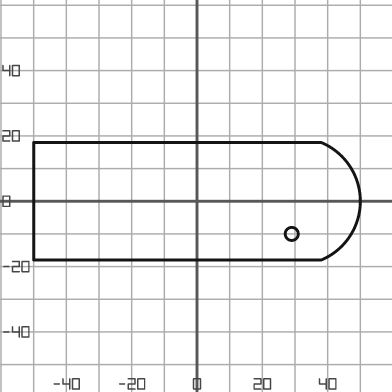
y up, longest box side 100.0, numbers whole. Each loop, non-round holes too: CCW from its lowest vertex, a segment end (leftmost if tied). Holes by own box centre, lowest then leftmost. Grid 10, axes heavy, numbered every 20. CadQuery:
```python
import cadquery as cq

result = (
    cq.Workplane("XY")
    .moveTo(-50.0, -18.0)
    .lineTo(38.0, -18.0)
    .threePointArc((50.0, 0.0), (38.0, 18.0))
    .lineTo(-50.0, 18.0)
    .close()
    .moveTo(29.0, -10.0)
    .circle(2.0)
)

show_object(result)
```